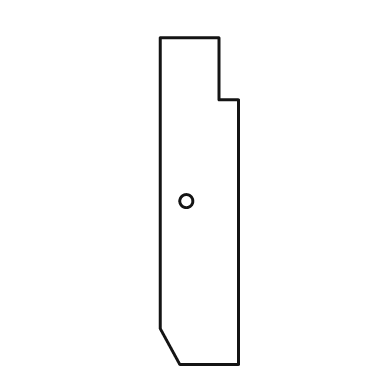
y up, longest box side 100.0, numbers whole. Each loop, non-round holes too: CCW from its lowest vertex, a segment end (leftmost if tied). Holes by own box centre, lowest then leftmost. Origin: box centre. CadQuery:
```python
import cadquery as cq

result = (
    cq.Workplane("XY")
    .moveTo(-6.0, -50.0)
    .lineTo(12.0, -50.0)
    .lineTo(12.0, 31.0)
    .lineTo(6.0, 31.0)
    .lineTo(6.0, 50.0)
    .lineTo(-12.0, 50.0)
    .lineTo(-12.0, -39.0)
    .close()
    .moveTo(-4.0, 0.0)
    .circle(2.0)
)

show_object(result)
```